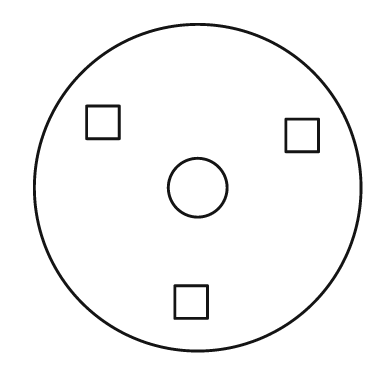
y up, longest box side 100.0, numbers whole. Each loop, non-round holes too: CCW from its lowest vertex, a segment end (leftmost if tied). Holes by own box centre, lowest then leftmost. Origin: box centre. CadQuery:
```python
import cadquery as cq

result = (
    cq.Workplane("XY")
    .moveTo(0.0, 0.0)
    .circle(50.0)
    .moveTo(-7.0, -40.0)
    .lineTo(3.0, -40.0)
    .lineTo(3.0, -30.0)
    .lineTo(-7.0, -30.0)
    .close()
    .moveTo(0.0, 0.0)
    .circle(9.0)
    .moveTo(27.0, 11.0)
    .lineTo(37.0, 11.0)
    .lineTo(37.0, 21.0)
    .lineTo(27.0, 21.0)
    .close()
    .moveTo(-34.0, 15.0)
    .lineTo(-24.0, 15.0)
    .lineTo(-24.0, 25.0)
    .lineTo(-34.0, 25.0)
    .close()
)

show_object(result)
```